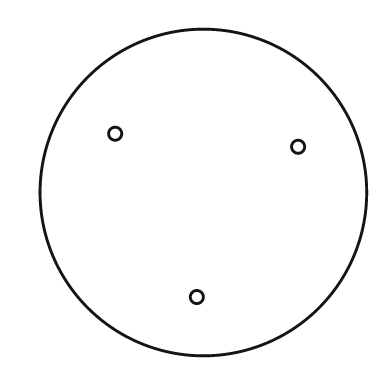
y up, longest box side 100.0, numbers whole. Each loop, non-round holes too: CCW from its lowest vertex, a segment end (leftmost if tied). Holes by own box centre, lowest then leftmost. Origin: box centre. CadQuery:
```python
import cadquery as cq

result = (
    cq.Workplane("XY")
    .moveTo(0.0, 0.0)
    .circle(50.0)
    .moveTo(-2.0, -32.0)
    .circle(2.0)
    .moveTo(29.0, 14.0)
    .circle(2.0)
    .moveTo(-27.0, 18.0)
    .circle(2.0)
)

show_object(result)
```